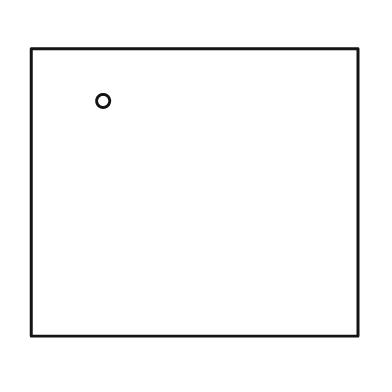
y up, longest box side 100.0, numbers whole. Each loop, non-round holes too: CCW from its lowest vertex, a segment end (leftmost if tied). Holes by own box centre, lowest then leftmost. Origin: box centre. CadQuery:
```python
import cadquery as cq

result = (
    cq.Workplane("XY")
    .moveTo(-50.0, -44.0)
    .lineTo(50.0, -44.0)
    .lineTo(50.0, 44.0)
    .lineTo(-50.0, 44.0)
    .close()
    .moveTo(-28.0, 28.0)
    .circle(2.0)
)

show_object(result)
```